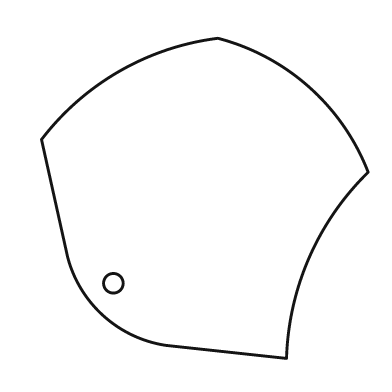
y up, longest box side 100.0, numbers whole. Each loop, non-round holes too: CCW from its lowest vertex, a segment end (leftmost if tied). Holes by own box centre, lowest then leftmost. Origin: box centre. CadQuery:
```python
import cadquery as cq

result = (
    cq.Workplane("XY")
    .moveTo(25.0, -49.0)
    .threePointArc((32.0, -18.0), (50.0, 8.0))
    .threePointArc((32.0, 34.0), (4.0, 49.0))
    .threePointArc((-26.0, 39.0), (-50.0, 18.0))
    .lineTo(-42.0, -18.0)
    .threePointArc((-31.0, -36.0), (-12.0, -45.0))
    .close()
    .moveTo(-28.0, -26.0)
    .circle(3.0)
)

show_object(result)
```